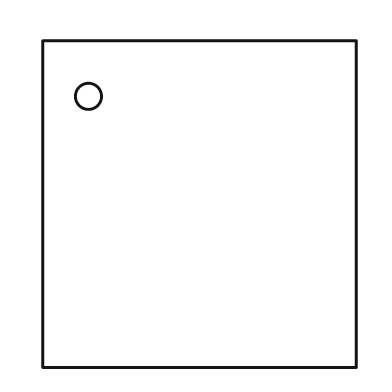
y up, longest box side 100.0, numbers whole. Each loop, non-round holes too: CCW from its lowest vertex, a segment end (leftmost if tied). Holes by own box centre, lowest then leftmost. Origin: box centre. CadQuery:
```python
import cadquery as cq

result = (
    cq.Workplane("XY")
    .moveTo(-48.0, -50.0)
    .lineTo(48.0, -50.0)
    .lineTo(48.0, 50.0)
    .lineTo(-48.0, 50.0)
    .close()
    .moveTo(-34.0, 33.0)
    .circle(4.0)
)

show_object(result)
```